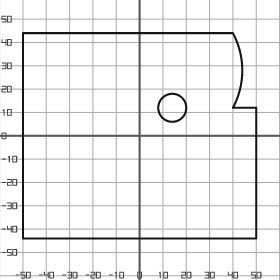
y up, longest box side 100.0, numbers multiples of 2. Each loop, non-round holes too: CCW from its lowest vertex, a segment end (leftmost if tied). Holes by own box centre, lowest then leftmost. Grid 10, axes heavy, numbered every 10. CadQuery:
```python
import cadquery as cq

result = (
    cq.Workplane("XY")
    .moveTo(-50.0, -44.0)
    .lineTo(50.0, -44.0)
    .lineTo(50.0, 12.0)
    .lineTo(40.0, 12.0)
    .threePointArc((44.0, 28.0), (40.0, 44.0))
    .lineTo(-50.0, 44.0)
    .close()
    .moveTo(14.0, 12.0)
    .circle(6.0)
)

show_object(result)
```